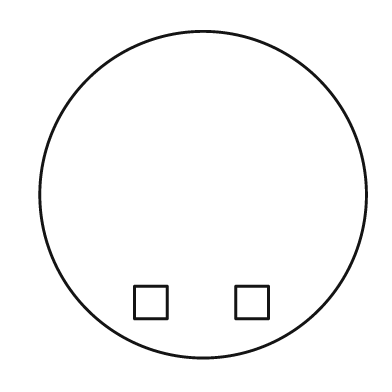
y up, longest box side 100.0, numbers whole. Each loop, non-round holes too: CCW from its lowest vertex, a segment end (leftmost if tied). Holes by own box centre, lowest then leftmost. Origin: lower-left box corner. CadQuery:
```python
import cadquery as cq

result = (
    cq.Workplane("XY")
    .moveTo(50.0, 50.0)
    .circle(50.0)
    .moveTo(29.0, 12.0)
    .lineTo(39.0, 12.0)
    .lineTo(39.0, 22.0)
    .lineTo(29.0, 22.0)
    .close()
    .moveTo(60.0, 12.0)
    .lineTo(70.0, 12.0)
    .lineTo(70.0, 22.0)
    .lineTo(60.0, 22.0)
    .close()
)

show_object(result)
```